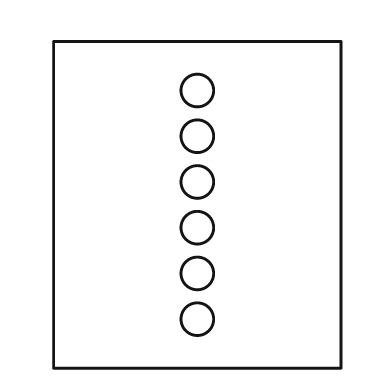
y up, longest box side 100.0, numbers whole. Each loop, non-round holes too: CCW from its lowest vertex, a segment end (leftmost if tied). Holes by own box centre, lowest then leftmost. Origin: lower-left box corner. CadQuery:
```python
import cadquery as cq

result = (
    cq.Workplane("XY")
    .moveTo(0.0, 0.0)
    .lineTo(88.0, 0.0)
    .lineTo(88.0, 100.0)
    .lineTo(0.0, 100.0)
    .close()
    .moveTo(44.0, 15.0)
    .circle(5.0)
    .moveTo(44.0, 29.0)
    .circle(5.0)
    .moveTo(44.0, 43.0)
    .circle(5.0)
    .moveTo(44.0, 57.0)
    .circle(5.0)
    .moveTo(44.0, 71.0)
    .circle(5.0)
    .moveTo(44.0, 85.0)
    .circle(5.0)
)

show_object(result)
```